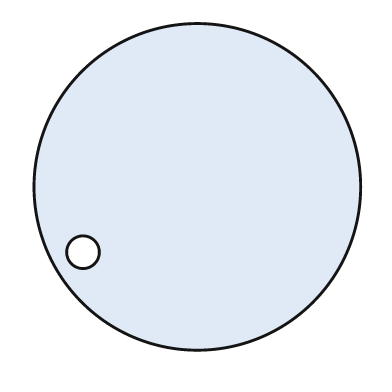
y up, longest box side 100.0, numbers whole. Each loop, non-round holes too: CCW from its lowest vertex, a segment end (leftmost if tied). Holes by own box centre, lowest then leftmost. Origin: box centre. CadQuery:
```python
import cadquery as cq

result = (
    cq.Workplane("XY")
    .moveTo(0.0, 0.0)
    .circle(50.0)
    .moveTo(-35.0, -20.0)
    .circle(5.0)
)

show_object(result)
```